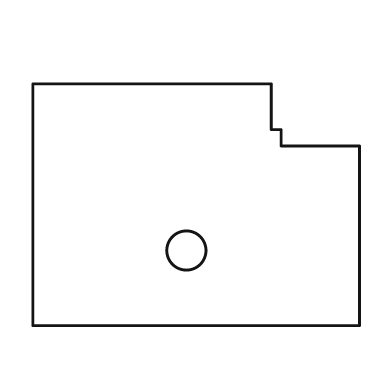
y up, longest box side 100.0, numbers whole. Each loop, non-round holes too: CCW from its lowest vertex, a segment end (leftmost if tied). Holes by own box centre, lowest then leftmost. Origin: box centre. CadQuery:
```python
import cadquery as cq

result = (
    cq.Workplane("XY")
    .moveTo(-50.0, -37.0)
    .lineTo(50.0, -37.0)
    .lineTo(50.0, 18.0)
    .lineTo(26.0, 18.0)
    .lineTo(26.0, 23.0)
    .lineTo(23.0, 23.0)
    .lineTo(23.0, 37.0)
    .lineTo(-50.0, 37.0)
    .close()
    .moveTo(-3.0, -14.0)
    .circle(6.0)
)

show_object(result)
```